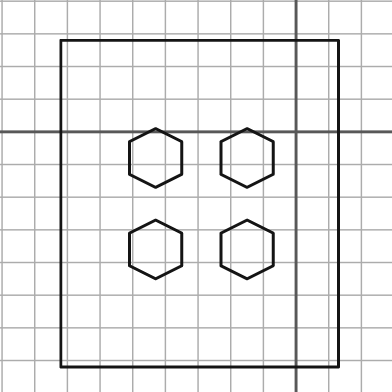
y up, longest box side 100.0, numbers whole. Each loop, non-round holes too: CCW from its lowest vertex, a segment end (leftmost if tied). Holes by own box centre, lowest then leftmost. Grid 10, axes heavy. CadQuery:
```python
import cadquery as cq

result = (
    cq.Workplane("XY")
    .moveTo(-72.0, -72.0)
    .lineTo(13.0, -72.0)
    .lineTo(13.0, 28.0)
    .lineTo(-72.0, 28.0)
    .close()
    .moveTo(-43.0, -45.0)
    .lineTo(-35.0, -41.0)
    .lineTo(-35.0, -31.0)
    .lineTo(-43.0, -27.0)
    .lineTo(-51.0, -31.0)
    .lineTo(-51.0, -41.0)
    .close()
    .moveTo(-15.0, -45.0)
    .lineTo(-7.0, -41.0)
    .lineTo(-7.0, -31.0)
    .lineTo(-15.0, -27.0)
    .lineTo(-23.0, -31.0)
    .lineTo(-23.0, -41.0)
    .close()
    .moveTo(-43.0, -17.0)
    .lineTo(-35.0, -13.0)
    .lineTo(-35.0, -3.0)
    .lineTo(-43.0, 1.0)
    .lineTo(-51.0, -3.0)
    .lineTo(-51.0, -13.0)
    .close()
    .moveTo(-15.0, -17.0)
    .lineTo(-7.0, -13.0)
    .lineTo(-7.0, -3.0)
    .lineTo(-15.0, 1.0)
    .lineTo(-23.0, -3.0)
    .lineTo(-23.0, -13.0)
    .close()
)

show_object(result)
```